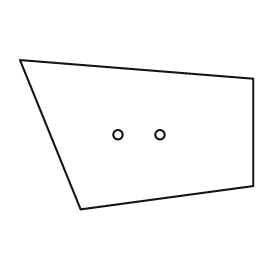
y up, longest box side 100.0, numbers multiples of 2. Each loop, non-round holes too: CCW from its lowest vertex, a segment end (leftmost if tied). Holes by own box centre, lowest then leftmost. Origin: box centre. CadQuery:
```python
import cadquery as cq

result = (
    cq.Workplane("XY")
    .moveTo(-24.0, -32.0)
    .lineTo(50.0, -22.0)
    .lineTo(50.0, 24.0)
    .lineTo(-50.0, 32.0)
    .close()
    .moveTo(-8.0, 0.0)
    .circle(2.0)
    .moveTo(10.0, 0.0)
    .circle(2.0)
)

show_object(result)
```